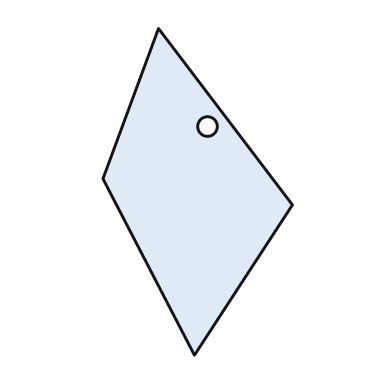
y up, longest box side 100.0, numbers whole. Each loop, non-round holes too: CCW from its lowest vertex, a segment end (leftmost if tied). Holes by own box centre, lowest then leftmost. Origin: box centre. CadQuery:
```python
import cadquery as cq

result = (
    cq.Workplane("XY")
    .moveTo(-1.0, -50.0)
    .lineTo(29.0, -4.0)
    .lineTo(-12.0, 50.0)
    .lineTo(-29.0, 4.0)
    .close()
    .moveTo(3.0, 20.0)
    .circle(3.0)
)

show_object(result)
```